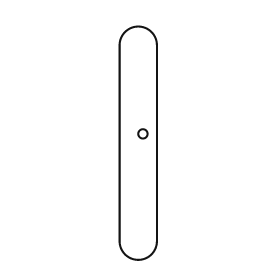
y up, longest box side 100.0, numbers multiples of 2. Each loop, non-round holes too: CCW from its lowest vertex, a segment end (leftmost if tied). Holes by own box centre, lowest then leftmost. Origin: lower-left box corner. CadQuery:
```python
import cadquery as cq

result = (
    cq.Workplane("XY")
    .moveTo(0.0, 8.0)
    .threePointArc((8.0, 0.0), (16.0, 8.0))
    .lineTo(16.0, 92.0)
    .threePointArc((8.0, 100.0), (0.0, 92.0))
    .close()
    .moveTo(10.0, 54.0)
    .circle(2.0)
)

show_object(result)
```